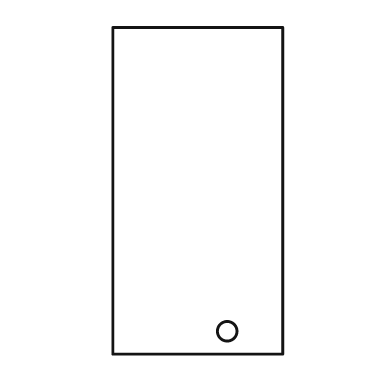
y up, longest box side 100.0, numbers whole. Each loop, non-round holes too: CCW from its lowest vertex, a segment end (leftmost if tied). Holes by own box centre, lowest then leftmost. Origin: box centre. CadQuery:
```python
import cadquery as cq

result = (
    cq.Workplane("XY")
    .moveTo(-26.0, -50.0)
    .lineTo(26.0, -50.0)
    .lineTo(26.0, 50.0)
    .lineTo(-26.0, 50.0)
    .close()
    .moveTo(9.0, -43.0)
    .circle(3.0)
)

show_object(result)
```